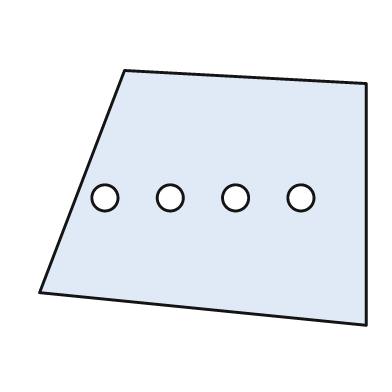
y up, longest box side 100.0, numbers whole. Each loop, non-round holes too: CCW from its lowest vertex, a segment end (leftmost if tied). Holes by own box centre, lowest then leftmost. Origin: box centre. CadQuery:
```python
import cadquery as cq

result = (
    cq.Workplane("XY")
    .moveTo(50.0, -39.0)
    .lineTo(50.0, 35.0)
    .lineTo(-24.0, 39.0)
    .lineTo(-50.0, -29.0)
    .close()
    .moveTo(-30.0, 0.0)
    .circle(4.0)
    .moveTo(-10.0, 0.0)
    .circle(4.0)
    .moveTo(10.0, 0.0)
    .circle(4.0)
    .moveTo(30.0, 0.0)
    .circle(4.0)
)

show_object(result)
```